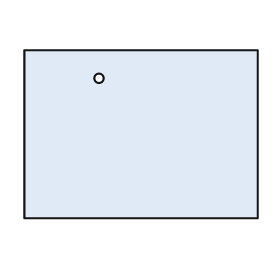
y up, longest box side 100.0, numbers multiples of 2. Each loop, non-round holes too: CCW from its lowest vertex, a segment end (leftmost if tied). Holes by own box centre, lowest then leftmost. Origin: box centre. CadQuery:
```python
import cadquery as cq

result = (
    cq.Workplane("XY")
    .moveTo(-50.0, -36.0)
    .lineTo(50.0, -36.0)
    .lineTo(50.0, 36.0)
    .lineTo(-50.0, 36.0)
    .close()
    .moveTo(-18.0, 24.0)
    .circle(2.0)
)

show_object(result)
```